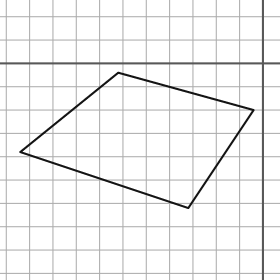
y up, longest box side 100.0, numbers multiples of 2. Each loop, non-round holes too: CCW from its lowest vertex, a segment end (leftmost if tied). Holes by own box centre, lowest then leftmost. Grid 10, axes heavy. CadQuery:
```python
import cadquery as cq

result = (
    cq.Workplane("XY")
    .moveTo(-32.0, -62.0)
    .lineTo(-4.0, -20.0)
    .lineTo(-62.0, -4.0)
    .lineTo(-104.0, -38.0)
    .close()
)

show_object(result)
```